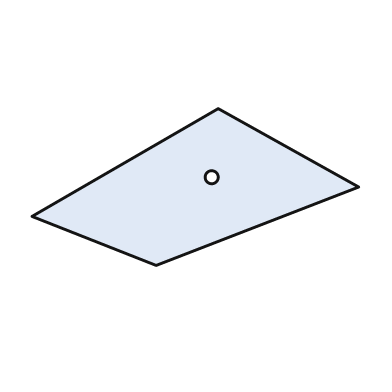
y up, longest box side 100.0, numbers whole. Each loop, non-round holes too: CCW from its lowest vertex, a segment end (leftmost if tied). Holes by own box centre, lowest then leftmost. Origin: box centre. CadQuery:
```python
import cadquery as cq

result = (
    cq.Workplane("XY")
    .moveTo(-12.0, -24.0)
    .lineTo(50.0, 0.0)
    .lineTo(7.0, 24.0)
    .lineTo(-50.0, -9.0)
    .close()
    .moveTo(5.0, 3.0)
    .circle(2.0)
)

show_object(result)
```